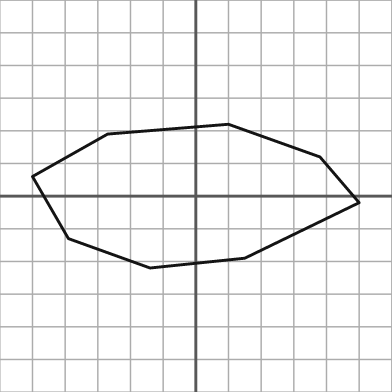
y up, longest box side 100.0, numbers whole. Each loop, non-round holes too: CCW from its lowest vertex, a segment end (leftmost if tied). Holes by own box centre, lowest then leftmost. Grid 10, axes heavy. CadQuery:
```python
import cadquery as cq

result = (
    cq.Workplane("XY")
    .moveTo(-14.0, -22.0)
    .lineTo(15.0, -19.0)
    .lineTo(50.0, -2.0)
    .lineTo(38.0, 12.0)
    .lineTo(10.0, 22.0)
    .lineTo(-27.0, 19.0)
    .lineTo(-50.0, 6.0)
    .lineTo(-39.0, -13.0)
    .close()
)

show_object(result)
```